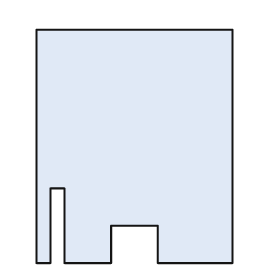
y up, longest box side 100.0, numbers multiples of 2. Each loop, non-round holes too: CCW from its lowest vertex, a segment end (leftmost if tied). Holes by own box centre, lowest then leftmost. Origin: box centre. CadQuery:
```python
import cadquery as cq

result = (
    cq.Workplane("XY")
    .moveTo(-42.0, -50.0)
    .lineTo(-36.0, -50.0)
    .lineTo(-36.0, -18.0)
    .lineTo(-30.0, -18.0)
    .lineTo(-30.0, -50.0)
    .lineTo(-10.0, -50.0)
    .lineTo(-10.0, -34.0)
    .lineTo(10.0, -34.0)
    .lineTo(10.0, -50.0)
    .lineTo(42.0, -50.0)
    .lineTo(42.0, 50.0)
    .lineTo(-42.0, 50.0)
    .close()
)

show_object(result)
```